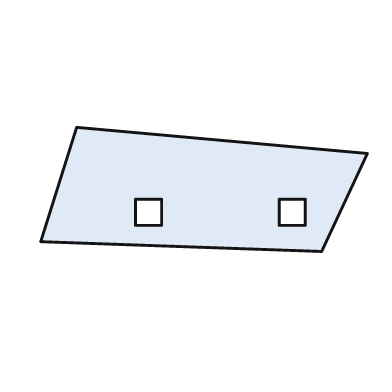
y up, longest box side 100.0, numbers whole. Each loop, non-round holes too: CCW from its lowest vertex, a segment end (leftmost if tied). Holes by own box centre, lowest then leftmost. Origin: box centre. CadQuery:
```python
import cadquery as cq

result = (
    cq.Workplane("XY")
    .moveTo(36.0, -19.0)
    .lineTo(50.0, 11.0)
    .lineTo(-39.0, 19.0)
    .lineTo(-50.0, -16.0)
    .close()
    .moveTo(-21.0, -11.0)
    .lineTo(-13.0, -11.0)
    .lineTo(-13.0, -3.0)
    .lineTo(-21.0, -3.0)
    .close()
    .moveTo(23.0, -11.0)
    .lineTo(31.0, -11.0)
    .lineTo(31.0, -3.0)
    .lineTo(23.0, -3.0)
    .close()
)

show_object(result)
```